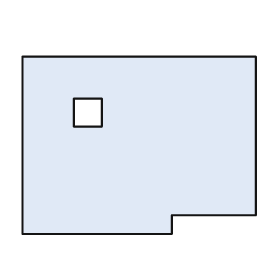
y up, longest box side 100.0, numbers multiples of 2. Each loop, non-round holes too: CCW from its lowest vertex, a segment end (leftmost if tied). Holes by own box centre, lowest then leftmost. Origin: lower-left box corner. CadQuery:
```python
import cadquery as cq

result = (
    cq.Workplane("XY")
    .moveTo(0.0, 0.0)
    .lineTo(64.0, 0.0)
    .lineTo(64.0, 8.0)
    .lineTo(100.0, 8.0)
    .lineTo(100.0, 76.0)
    .lineTo(0.0, 76.0)
    .close()
    .moveTo(22.0, 46.0)
    .lineTo(34.0, 46.0)
    .lineTo(34.0, 58.0)
    .lineTo(22.0, 58.0)
    .close()
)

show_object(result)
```